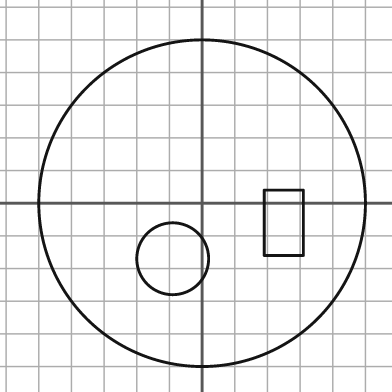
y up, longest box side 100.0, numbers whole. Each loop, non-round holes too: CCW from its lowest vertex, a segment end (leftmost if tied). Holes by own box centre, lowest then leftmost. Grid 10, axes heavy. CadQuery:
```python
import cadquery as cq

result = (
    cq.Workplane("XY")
    .moveTo(0.0, 0.0)
    .circle(50.0)
    .moveTo(-9.0, -17.0)
    .circle(11.0)
    .moveTo(19.0, -16.0)
    .lineTo(31.0, -16.0)
    .lineTo(31.0, 4.0)
    .lineTo(19.0, 4.0)
    .close()
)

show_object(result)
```